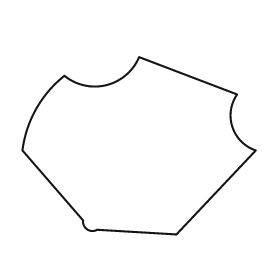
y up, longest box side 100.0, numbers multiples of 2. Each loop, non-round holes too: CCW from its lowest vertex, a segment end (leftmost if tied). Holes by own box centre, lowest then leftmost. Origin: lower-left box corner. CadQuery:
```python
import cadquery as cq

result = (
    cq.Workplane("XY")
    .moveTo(66.0, 0.0)
    .lineTo(100.0, 36.0)
    .threePointArc((90.0, 46.0), (92.0, 60.0))
    .lineTo(50.0, 76.0)
    .threePointArc((36.0, 64.0), (18.0, 68.0))
    .threePointArc((6.0, 54.0), (0.0, 36.0))
    .lineTo(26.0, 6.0)
    .threePointArc((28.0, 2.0), (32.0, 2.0))
    .close()
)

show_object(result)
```